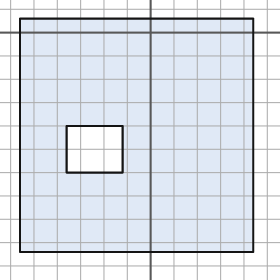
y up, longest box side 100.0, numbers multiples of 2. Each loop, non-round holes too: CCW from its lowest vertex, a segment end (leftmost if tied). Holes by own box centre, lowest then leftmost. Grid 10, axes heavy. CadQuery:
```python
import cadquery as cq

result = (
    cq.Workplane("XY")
    .moveTo(-56.0, -94.0)
    .lineTo(44.0, -94.0)
    .lineTo(44.0, 6.0)
    .lineTo(-56.0, 6.0)
    .close()
    .moveTo(-36.0, -60.0)
    .lineTo(-12.0, -60.0)
    .lineTo(-12.0, -40.0)
    .lineTo(-36.0, -40.0)
    .close()
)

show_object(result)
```